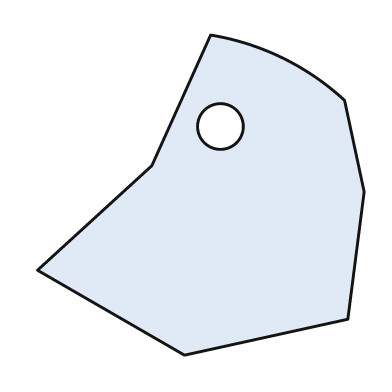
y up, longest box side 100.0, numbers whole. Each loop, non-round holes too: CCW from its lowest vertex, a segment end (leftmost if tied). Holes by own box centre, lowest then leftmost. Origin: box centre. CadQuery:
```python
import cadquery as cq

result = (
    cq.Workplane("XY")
    .moveTo(-5.0, -49.0)
    .lineTo(45.0, -38.0)
    .lineTo(50.0, 1.0)
    .lineTo(44.0, 29.0)
    .threePointArc((25.0, 42.0), (3.0, 49.0))
    .lineTo(-15.0, 9.0)
    .lineTo(-50.0, -23.0)
    .close()
    .moveTo(6.0, 21.0)
    .circle(7.0)
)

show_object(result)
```